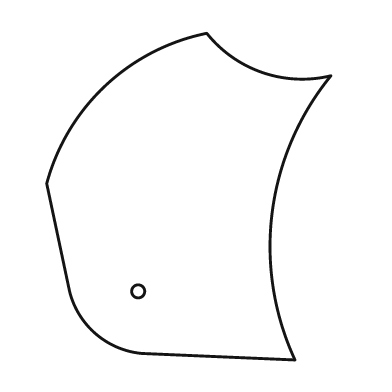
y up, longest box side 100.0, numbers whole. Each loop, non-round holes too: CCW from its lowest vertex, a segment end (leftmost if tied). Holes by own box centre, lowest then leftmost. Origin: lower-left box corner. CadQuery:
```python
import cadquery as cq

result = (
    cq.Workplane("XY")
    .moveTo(76.0, 0.0)
    .threePointArc((69.0, 45.0), (87.0, 87.0))
    .threePointArc((66.0, 88.0), (49.0, 100.0))
    .threePointArc((18.0, 84.0), (0.0, 54.0))
    .lineTo(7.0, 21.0)
    .threePointArc((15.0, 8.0), (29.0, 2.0))
    .close()
    .moveTo(28.0, 21.0)
    .circle(2.0)
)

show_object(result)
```